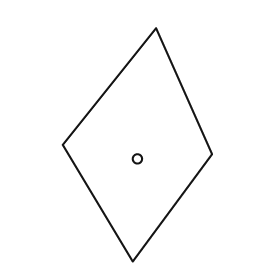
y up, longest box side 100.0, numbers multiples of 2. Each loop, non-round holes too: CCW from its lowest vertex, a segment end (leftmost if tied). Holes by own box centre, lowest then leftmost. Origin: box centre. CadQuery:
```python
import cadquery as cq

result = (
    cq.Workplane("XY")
    .moveTo(-2.0, -50.0)
    .lineTo(32.0, -4.0)
    .lineTo(8.0, 50.0)
    .lineTo(-32.0, 0.0)
    .close()
    .moveTo(0.0, -6.0)
    .circle(2.0)
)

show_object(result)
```